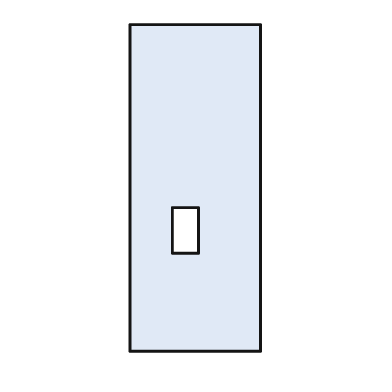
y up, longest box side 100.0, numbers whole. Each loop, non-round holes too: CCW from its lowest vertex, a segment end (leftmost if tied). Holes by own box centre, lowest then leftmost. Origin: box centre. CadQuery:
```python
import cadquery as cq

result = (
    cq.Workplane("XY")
    .moveTo(-20.0, -50.0)
    .lineTo(20.0, -50.0)
    .lineTo(20.0, 50.0)
    .lineTo(-20.0, 50.0)
    .close()
    .moveTo(-7.0, -20.0)
    .lineTo(1.0, -20.0)
    .lineTo(1.0, -6.0)
    .lineTo(-7.0, -6.0)
    .close()
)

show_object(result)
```